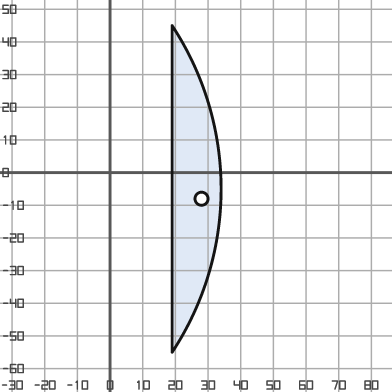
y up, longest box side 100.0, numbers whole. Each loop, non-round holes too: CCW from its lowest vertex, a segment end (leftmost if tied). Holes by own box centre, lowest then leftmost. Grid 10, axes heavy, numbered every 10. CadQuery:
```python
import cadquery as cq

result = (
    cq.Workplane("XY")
    .moveTo(19.0, -55.0)
    .threePointArc((34.0, -5.0), (19.0, 45.0))
    .close()
    .moveTo(28.0, -8.0)
    .circle(2.0)
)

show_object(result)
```